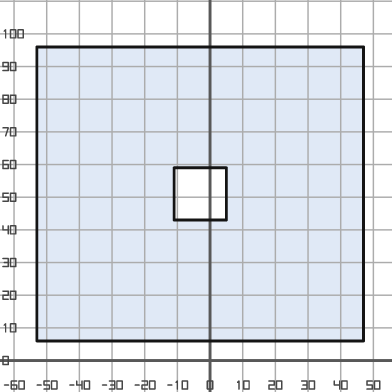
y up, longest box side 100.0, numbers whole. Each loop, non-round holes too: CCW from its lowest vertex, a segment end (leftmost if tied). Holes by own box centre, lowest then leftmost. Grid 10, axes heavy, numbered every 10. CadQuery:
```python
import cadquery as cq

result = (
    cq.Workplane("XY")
    .moveTo(-53.0, 6.0)
    .lineTo(47.0, 6.0)
    .lineTo(47.0, 96.0)
    .lineTo(-53.0, 96.0)
    .close()
    .moveTo(-11.0, 43.0)
    .lineTo(5.0, 43.0)
    .lineTo(5.0, 59.0)
    .lineTo(-11.0, 59.0)
    .close()
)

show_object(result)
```